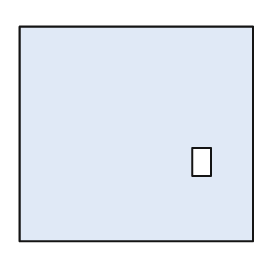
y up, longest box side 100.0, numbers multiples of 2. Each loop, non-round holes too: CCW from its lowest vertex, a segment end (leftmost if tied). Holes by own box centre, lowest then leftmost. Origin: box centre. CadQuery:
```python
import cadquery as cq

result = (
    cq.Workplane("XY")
    .moveTo(-50.0, -46.0)
    .lineTo(50.0, -46.0)
    .lineTo(50.0, 46.0)
    .lineTo(-50.0, 46.0)
    .close()
    .moveTo(24.0, -18.0)
    .lineTo(32.0, -18.0)
    .lineTo(32.0, -6.0)
    .lineTo(24.0, -6.0)
    .close()
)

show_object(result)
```